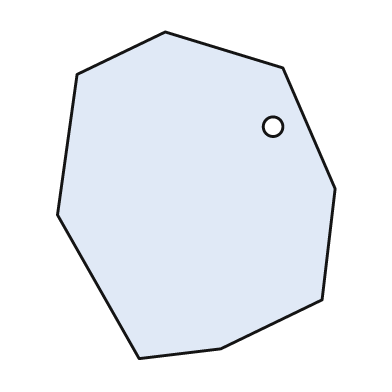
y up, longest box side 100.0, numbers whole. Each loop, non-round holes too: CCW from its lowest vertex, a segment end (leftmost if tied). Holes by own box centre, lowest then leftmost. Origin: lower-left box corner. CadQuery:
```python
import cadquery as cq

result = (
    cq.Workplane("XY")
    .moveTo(25.0, 0.0)
    .lineTo(50.0, 3.0)
    .lineTo(81.0, 18.0)
    .lineTo(85.0, 52.0)
    .lineTo(69.0, 89.0)
    .lineTo(33.0, 100.0)
    .lineTo(6.0, 87.0)
    .lineTo(0.0, 44.0)
    .close()
    .moveTo(66.0, 71.0)
    .circle(3.0)
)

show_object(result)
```